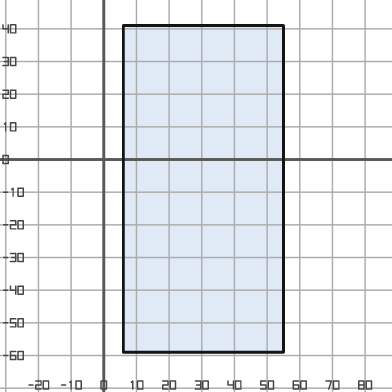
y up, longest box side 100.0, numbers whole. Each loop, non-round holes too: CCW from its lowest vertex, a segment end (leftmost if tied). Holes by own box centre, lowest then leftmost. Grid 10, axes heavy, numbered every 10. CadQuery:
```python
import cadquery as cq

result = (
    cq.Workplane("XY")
    .moveTo(6.0, -59.0)
    .lineTo(55.0, -59.0)
    .lineTo(55.0, 41.0)
    .lineTo(6.0, 41.0)
    .close()
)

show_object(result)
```